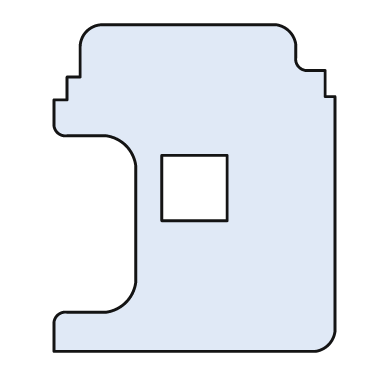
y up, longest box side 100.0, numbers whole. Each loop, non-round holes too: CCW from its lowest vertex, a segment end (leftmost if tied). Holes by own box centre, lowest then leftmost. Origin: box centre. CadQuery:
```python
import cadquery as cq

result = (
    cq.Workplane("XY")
    .moveTo(-43.0, -50.0)
    .lineTo(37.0, -50.0)
    .threePointArc((41.0, -48.0), (43.0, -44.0))
    .lineTo(43.0, 28.0)
    .lineTo(40.0, 28.0)
    .lineTo(40.0, 36.0)
    .lineTo(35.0, 36.0)
    .threePointArc((32.0, 37.0), (31.0, 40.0))
    .lineTo(31.0, 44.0)
    .threePointArc((29.0, 48.0), (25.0, 50.0))
    .lineTo(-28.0, 50.0)
    .threePointArc((-33.0, 48.0), (-35.0, 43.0))
    .lineTo(-35.0, 34.0)
    .lineTo(-39.0, 34.0)
    .lineTo(-39.0, 27.0)
    .lineTo(-43.0, 27.0)
    .lineTo(-43.0, 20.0)
    .threePointArc((-42.0, 17.0), (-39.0, 16.0))
    .lineTo(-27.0, 16.0)
    .threePointArc((-21.0, 13.0), (-18.0, 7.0))
    .lineTo(-18.0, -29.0)
    .threePointArc((-21.0, -35.0), (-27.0, -38.0))
    .lineTo(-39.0, -38.0)
    .threePointArc((-42.0, -39.0), (-43.0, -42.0))
    .close()
    .moveTo(-10.0, -10.0)
    .lineTo(10.0, -10.0)
    .lineTo(10.0, 10.0)
    .lineTo(-10.0, 10.0)
    .close()
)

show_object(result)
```